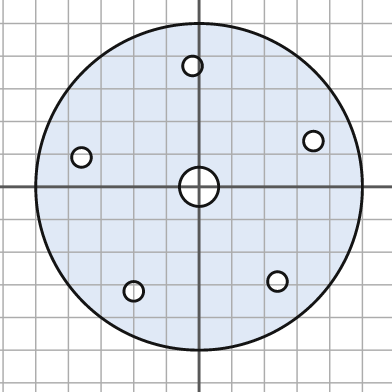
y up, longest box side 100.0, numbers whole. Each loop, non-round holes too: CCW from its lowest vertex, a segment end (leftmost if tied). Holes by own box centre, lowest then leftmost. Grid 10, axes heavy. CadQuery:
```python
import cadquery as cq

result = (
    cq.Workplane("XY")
    .moveTo(0.0, 0.0)
    .circle(50.0)
    .moveTo(-20.0, -32.0)
    .circle(3.0)
    .moveTo(24.0, -29.0)
    .circle(3.0)
    .moveTo(0.0, 0.0)
    .circle(6.0)
    .moveTo(-36.0, 9.0)
    .circle(3.0)
    .moveTo(35.0, 14.0)
    .circle(3.0)
    .moveTo(-2.0, 37.0)
    .circle(3.0)
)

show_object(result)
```